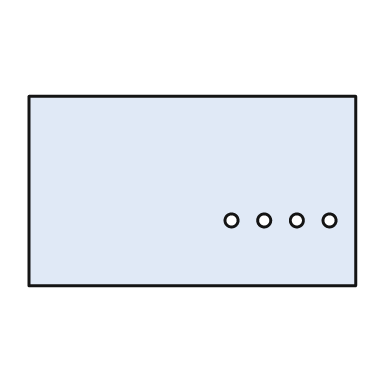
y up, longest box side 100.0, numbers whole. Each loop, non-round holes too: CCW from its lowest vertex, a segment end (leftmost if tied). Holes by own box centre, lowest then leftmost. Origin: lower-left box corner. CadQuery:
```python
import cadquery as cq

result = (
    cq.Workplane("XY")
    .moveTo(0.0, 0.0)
    .lineTo(100.0, 0.0)
    .lineTo(100.0, 58.0)
    .lineTo(0.0, 58.0)
    .close()
    .moveTo(62.0, 20.0)
    .circle(2.0)
    .moveTo(72.0, 20.0)
    .circle(2.0)
    .moveTo(82.0, 20.0)
    .circle(2.0)
    .moveTo(92.0, 20.0)
    .circle(2.0)
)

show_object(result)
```